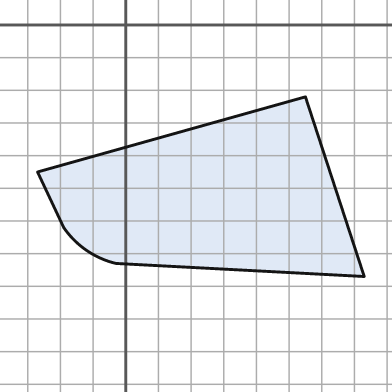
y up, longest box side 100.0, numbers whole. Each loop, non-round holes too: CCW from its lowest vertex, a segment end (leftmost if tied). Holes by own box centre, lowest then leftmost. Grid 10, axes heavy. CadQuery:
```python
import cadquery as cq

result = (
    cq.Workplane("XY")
    .moveTo(73.0, -77.0)
    .lineTo(55.0, -22.0)
    .lineTo(-27.0, -45.0)
    .lineTo(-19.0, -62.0)
    .threePointArc((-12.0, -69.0), (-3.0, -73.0))
    .close()
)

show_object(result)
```